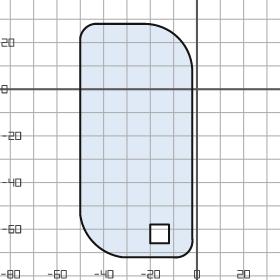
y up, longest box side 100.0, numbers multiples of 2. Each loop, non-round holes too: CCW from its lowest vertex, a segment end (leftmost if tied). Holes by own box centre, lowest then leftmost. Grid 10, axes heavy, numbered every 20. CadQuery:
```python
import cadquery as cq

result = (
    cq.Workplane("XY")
    .moveTo(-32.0, -72.0)
    .lineTo(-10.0, -72.0)
    .threePointArc((-4.0, -70.0), (-2.0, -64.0))
    .lineTo(-2.0, 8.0)
    .threePointArc((-8.0, 22.0), (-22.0, 28.0))
    .lineTo(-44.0, 28.0)
    .threePointArc((-48.0, 26.0), (-50.0, 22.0))
    .lineTo(-50.0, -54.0)
    .threePointArc((-44.0, -66.0), (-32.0, -72.0))
    .close()
    .moveTo(-20.0, -66.0)
    .lineTo(-12.0, -66.0)
    .lineTo(-12.0, -58.0)
    .lineTo(-20.0, -58.0)
    .close()
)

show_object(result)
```